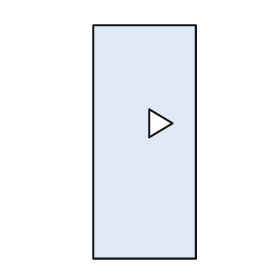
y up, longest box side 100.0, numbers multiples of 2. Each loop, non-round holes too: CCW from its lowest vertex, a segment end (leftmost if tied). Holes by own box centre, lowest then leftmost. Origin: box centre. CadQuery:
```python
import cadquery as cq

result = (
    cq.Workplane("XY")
    .moveTo(-22.0, -50.0)
    .lineTo(22.0, -50.0)
    .lineTo(22.0, 50.0)
    .lineTo(-22.0, 50.0)
    .close()
    .moveTo(2.0, 2.0)
    .lineTo(12.0, 8.0)
    .lineTo(2.0, 14.0)
    .close()
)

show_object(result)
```